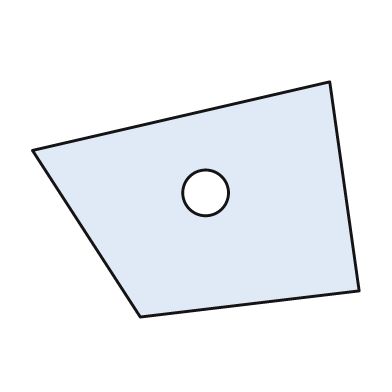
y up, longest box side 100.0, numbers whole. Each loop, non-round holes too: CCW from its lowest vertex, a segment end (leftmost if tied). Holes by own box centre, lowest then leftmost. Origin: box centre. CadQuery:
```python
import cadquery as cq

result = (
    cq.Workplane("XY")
    .moveTo(-17.0, -36.0)
    .lineTo(50.0, -28.0)
    .lineTo(41.0, 36.0)
    .lineTo(-50.0, 15.0)
    .close()
    .moveTo(3.0, 2.0)
    .circle(7.0)
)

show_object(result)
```